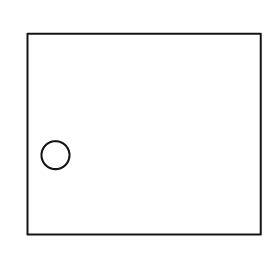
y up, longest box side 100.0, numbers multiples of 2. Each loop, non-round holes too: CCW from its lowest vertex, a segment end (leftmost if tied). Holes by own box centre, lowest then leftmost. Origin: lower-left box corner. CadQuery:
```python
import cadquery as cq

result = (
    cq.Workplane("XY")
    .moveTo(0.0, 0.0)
    .lineTo(100.0, 0.0)
    .lineTo(100.0, 86.0)
    .lineTo(0.0, 86.0)
    .close()
    .moveTo(12.0, 34.0)
    .circle(6.0)
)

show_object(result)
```